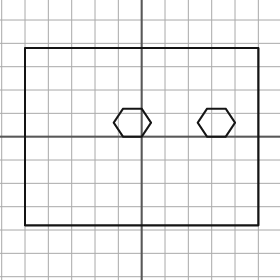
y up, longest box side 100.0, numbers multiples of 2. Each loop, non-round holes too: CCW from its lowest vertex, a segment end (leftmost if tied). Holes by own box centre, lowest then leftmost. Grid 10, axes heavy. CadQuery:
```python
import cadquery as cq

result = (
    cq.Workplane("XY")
    .moveTo(-50.0, -38.0)
    .lineTo(50.0, -38.0)
    .lineTo(50.0, 38.0)
    .lineTo(-50.0, 38.0)
    .close()
    .moveTo(-8.0, 0.0)
    .lineTo(0.0, 0.0)
    .lineTo(4.0, 6.0)
    .lineTo(0.0, 12.0)
    .lineTo(-8.0, 12.0)
    .lineTo(-12.0, 6.0)
    .close()
    .moveTo(28.0, 0.0)
    .lineTo(36.0, 0.0)
    .lineTo(40.0, 6.0)
    .lineTo(36.0, 12.0)
    .lineTo(28.0, 12.0)
    .lineTo(24.0, 6.0)
    .close()
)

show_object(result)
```